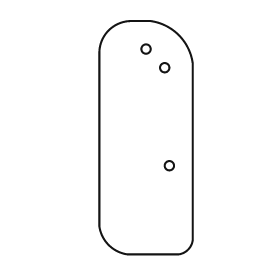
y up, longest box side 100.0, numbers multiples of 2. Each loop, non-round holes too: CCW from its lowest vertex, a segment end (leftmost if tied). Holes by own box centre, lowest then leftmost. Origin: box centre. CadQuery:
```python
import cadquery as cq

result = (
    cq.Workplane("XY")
    .moveTo(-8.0, -50.0)
    .lineTo(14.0, -50.0)
    .threePointArc((18.0, -48.0), (20.0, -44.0))
    .lineTo(20.0, 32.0)
    .threePointArc((14.0, 44.0), (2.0, 50.0))
    .lineTo(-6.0, 50.0)
    .threePointArc((-16.0, 46.0), (-20.0, 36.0))
    .lineTo(-20.0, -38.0)
    .threePointArc((-16.0, -46.0), (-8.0, -50.0))
    .close()
    .moveTo(10.0, -12.0)
    .circle(2.0)
    .moveTo(8.0, 30.0)
    .circle(2.0)
    .moveTo(0.0, 38.0)
    .circle(2.0)
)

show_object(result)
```